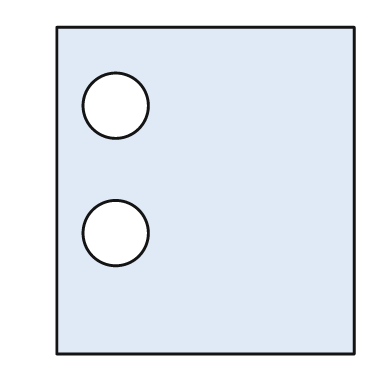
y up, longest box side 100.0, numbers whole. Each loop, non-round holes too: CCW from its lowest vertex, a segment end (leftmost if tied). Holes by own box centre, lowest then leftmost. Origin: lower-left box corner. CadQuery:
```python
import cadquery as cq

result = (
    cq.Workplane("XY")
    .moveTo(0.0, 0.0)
    .lineTo(91.0, 0.0)
    .lineTo(91.0, 100.0)
    .lineTo(0.0, 100.0)
    .close()
    .moveTo(18.0, 37.0)
    .circle(10.0)
    .moveTo(18.0, 76.0)
    .circle(10.0)
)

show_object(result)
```